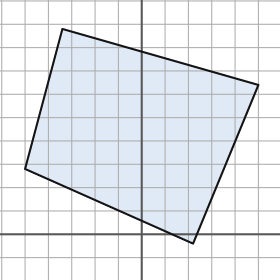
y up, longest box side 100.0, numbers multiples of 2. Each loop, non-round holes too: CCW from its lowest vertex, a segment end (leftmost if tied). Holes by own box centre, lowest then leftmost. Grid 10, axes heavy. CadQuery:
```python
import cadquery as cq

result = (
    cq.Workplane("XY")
    .moveTo(22.0, -4.0)
    .lineTo(50.0, 64.0)
    .lineTo(-34.0, 88.0)
    .lineTo(-50.0, 28.0)
    .close()
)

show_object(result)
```